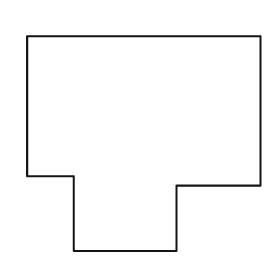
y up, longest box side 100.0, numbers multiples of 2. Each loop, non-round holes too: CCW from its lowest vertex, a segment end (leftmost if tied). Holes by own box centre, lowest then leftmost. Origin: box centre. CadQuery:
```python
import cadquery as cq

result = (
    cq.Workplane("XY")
    .moveTo(-30.0, -46.0)
    .lineTo(14.0, -46.0)
    .lineTo(14.0, -18.0)
    .lineTo(50.0, -18.0)
    .lineTo(50.0, 46.0)
    .lineTo(-50.0, 46.0)
    .lineTo(-50.0, -14.0)
    .lineTo(-30.0, -14.0)
    .close()
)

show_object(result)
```